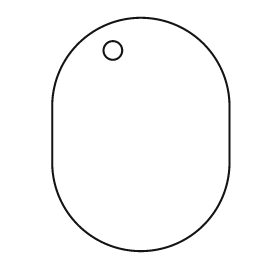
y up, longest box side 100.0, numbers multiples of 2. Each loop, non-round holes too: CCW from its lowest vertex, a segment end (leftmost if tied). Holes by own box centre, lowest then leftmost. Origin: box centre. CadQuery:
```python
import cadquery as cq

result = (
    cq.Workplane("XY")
    .moveTo(-38.0, -12.0)
    .threePointArc((0.0, -50.0), (38.0, -12.0))
    .lineTo(38.0, 12.0)
    .threePointArc((0.0, 50.0), (-38.0, 12.0))
    .close()
    .moveTo(-12.0, 36.0)
    .circle(4.0)
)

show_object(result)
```